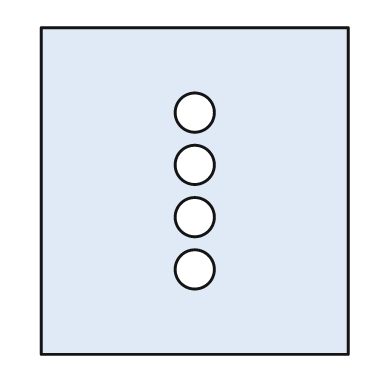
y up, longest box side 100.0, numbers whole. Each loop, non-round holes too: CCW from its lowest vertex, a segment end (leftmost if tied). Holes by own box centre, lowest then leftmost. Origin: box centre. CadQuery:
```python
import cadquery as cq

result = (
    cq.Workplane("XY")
    .moveTo(-47.0, -50.0)
    .lineTo(47.0, -50.0)
    .lineTo(47.0, 50.0)
    .lineTo(-47.0, 50.0)
    .close()
    .moveTo(0.0, -24.0)
    .circle(6.0)
    .moveTo(0.0, -8.0)
    .circle(6.0)
    .moveTo(0.0, 8.0)
    .circle(6.0)
    .moveTo(0.0, 24.0)
    .circle(6.0)
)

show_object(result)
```